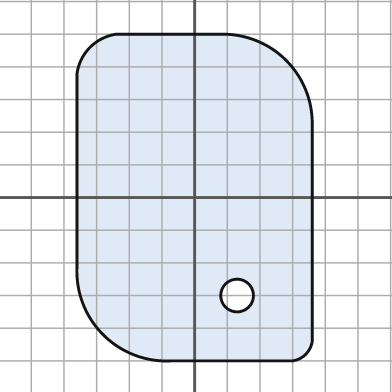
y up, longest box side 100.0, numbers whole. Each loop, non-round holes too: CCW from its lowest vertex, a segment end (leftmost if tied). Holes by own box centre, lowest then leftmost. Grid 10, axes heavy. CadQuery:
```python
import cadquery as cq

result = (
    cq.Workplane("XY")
    .moveTo(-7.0, -50.0)
    .lineTo(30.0, -50.0)
    .threePointArc((34.0, -48.0), (36.0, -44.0))
    .lineTo(36.0, 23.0)
    .threePointArc((28.0, 42.0), (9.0, 50.0))
    .lineTo(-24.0, 50.0)
    .threePointArc((-32.0, 46.0), (-36.0, 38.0))
    .lineTo(-36.0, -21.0)
    .threePointArc((-28.0, -42.0), (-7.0, -50.0))
    .close()
    .moveTo(13.0, -30.0)
    .circle(5.0)
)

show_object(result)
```